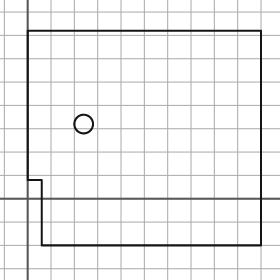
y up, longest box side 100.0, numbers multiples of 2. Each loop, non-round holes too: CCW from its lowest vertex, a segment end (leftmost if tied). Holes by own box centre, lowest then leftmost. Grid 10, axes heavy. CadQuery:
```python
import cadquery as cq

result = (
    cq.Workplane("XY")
    .moveTo(6.0, -20.0)
    .lineTo(100.0, -20.0)
    .lineTo(100.0, 72.0)
    .lineTo(0.0, 72.0)
    .lineTo(0.0, 8.0)
    .lineTo(6.0, 8.0)
    .close()
    .moveTo(24.0, 32.0)
    .circle(4.0)
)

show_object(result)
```